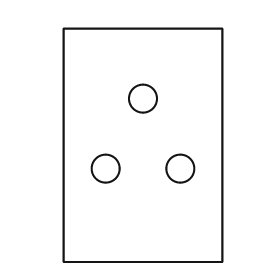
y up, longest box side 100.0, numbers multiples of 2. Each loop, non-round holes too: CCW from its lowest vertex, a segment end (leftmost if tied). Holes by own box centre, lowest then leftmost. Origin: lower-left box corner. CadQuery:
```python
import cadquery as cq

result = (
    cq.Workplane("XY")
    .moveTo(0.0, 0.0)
    .lineTo(68.0, 0.0)
    .lineTo(68.0, 100.0)
    .lineTo(0.0, 100.0)
    .close()
    .moveTo(18.0, 40.0)
    .circle(6.0)
    .moveTo(50.0, 40.0)
    .circle(6.0)
    .moveTo(34.0, 70.0)
    .circle(6.0)
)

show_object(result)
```